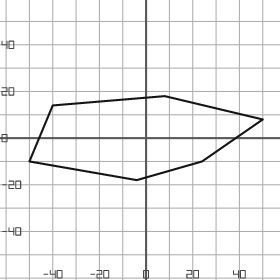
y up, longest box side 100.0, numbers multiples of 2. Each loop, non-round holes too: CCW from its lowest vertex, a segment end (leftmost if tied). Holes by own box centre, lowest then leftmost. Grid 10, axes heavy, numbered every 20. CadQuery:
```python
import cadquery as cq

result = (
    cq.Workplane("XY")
    .moveTo(-4.0, -18.0)
    .lineTo(24.0, -10.0)
    .lineTo(50.0, 8.0)
    .lineTo(8.0, 18.0)
    .lineTo(-40.0, 14.0)
    .lineTo(-50.0, -10.0)
    .close()
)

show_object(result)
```